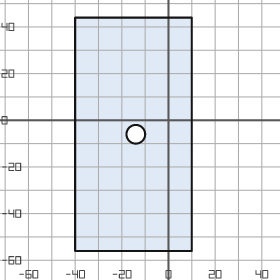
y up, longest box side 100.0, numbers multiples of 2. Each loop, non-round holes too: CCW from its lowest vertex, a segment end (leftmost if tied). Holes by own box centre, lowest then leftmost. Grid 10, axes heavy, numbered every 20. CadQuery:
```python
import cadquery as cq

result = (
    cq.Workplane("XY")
    .moveTo(-40.0, -56.0)
    .lineTo(10.0, -56.0)
    .lineTo(10.0, 44.0)
    .lineTo(-40.0, 44.0)
    .close()
    .moveTo(-14.0, -6.0)
    .circle(4.0)
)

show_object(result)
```